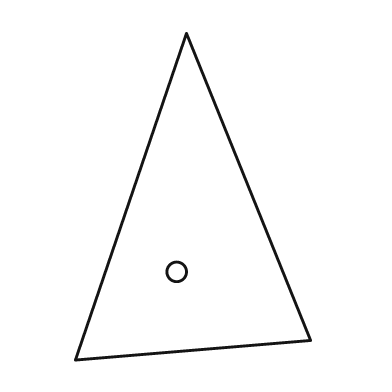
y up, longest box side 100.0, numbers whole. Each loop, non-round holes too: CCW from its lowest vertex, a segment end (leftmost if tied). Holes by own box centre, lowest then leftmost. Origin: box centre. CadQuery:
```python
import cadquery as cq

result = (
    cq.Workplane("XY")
    .moveTo(-36.0, -50.0)
    .lineTo(36.0, -44.0)
    .lineTo(-2.0, 50.0)
    .close()
    .moveTo(-5.0, -23.0)
    .circle(3.0)
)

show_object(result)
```